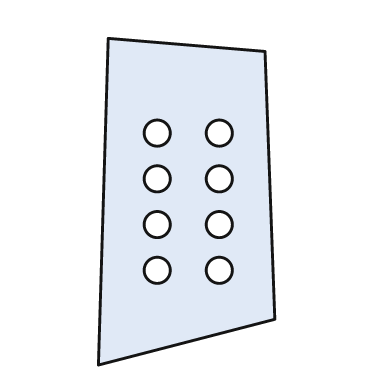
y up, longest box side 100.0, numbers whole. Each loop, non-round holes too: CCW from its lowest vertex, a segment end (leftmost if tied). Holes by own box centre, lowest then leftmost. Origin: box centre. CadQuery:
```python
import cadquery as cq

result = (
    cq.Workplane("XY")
    .moveTo(-27.0, -50.0)
    .lineTo(27.0, -36.0)
    .lineTo(24.0, 46.0)
    .lineTo(-24.0, 50.0)
    .close()
    .moveTo(-9.0, -21.0)
    .circle(4.0)
    .moveTo(10.0, -21.0)
    .circle(4.0)
    .moveTo(-9.0, -7.0)
    .circle(4.0)
    .moveTo(10.0, -7.0)
    .circle(4.0)
    .moveTo(-9.0, 7.0)
    .circle(4.0)
    .moveTo(10.0, 7.0)
    .circle(4.0)
    .moveTo(-9.0, 21.0)
    .circle(4.0)
    .moveTo(10.0, 21.0)
    .circle(4.0)
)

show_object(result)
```